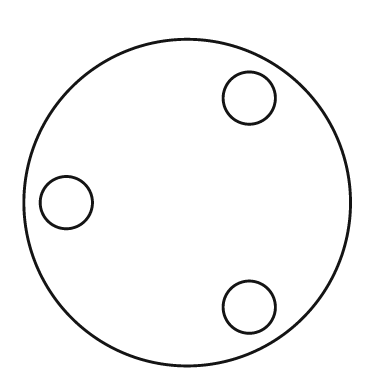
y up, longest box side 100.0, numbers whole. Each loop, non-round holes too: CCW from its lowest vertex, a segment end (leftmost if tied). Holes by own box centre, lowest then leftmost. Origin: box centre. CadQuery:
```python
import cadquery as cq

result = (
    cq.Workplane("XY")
    .moveTo(0.0, 0.0)
    .circle(50.0)
    .moveTo(19.0, -32.0)
    .circle(8.0)
    .moveTo(-37.0, 0.0)
    .circle(8.0)
    .moveTo(19.0, 32.0)
    .circle(8.0)
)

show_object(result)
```